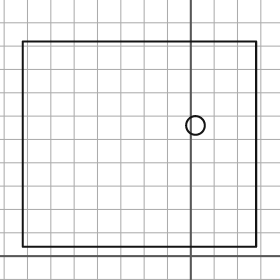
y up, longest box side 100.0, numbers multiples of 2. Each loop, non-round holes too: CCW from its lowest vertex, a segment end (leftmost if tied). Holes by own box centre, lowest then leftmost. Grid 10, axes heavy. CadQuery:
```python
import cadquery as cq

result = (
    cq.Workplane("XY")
    .moveTo(-72.0, 4.0)
    .lineTo(28.0, 4.0)
    .lineTo(28.0, 92.0)
    .lineTo(-72.0, 92.0)
    .close()
    .moveTo(2.0, 56.0)
    .circle(4.0)
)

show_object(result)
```